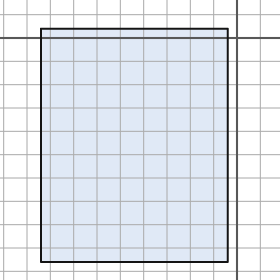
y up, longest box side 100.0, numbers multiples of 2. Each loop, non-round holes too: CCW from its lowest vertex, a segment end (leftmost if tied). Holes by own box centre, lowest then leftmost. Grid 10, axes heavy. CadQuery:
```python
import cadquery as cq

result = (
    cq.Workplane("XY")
    .moveTo(-84.0, -96.0)
    .lineTo(-4.0, -96.0)
    .lineTo(-4.0, 4.0)
    .lineTo(-84.0, 4.0)
    .close()
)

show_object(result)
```